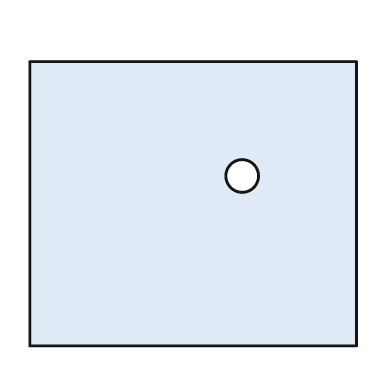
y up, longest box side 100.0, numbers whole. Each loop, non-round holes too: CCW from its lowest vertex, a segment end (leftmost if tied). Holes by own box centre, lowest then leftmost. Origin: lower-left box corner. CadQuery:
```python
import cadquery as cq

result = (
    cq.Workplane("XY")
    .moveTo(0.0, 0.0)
    .lineTo(100.0, 0.0)
    .lineTo(100.0, 87.0)
    .lineTo(0.0, 87.0)
    .close()
    .moveTo(65.0, 52.0)
    .circle(5.0)
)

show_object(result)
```